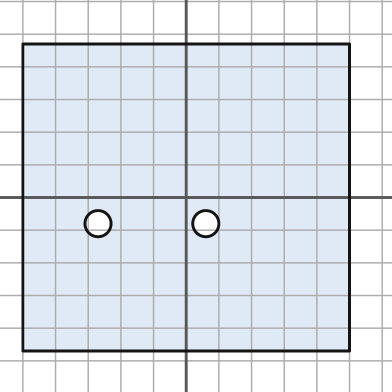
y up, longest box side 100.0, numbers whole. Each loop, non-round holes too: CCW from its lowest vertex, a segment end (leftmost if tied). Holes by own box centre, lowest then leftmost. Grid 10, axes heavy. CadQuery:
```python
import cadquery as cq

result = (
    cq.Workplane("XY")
    .moveTo(-50.0, -47.0)
    .lineTo(50.0, -47.0)
    .lineTo(50.0, 47.0)
    .lineTo(-50.0, 47.0)
    .close()
    .moveTo(-27.0, -8.0)
    .circle(4.0)
    .moveTo(6.0, -8.0)
    .circle(4.0)
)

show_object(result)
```